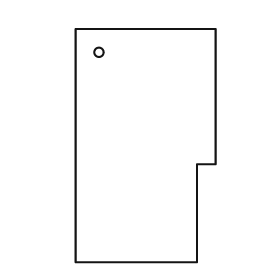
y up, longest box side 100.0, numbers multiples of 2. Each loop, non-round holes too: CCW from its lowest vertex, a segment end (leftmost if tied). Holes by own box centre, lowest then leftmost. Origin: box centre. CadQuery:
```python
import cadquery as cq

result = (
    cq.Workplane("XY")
    .moveTo(-30.0, -50.0)
    .lineTo(22.0, -50.0)
    .lineTo(22.0, -8.0)
    .lineTo(30.0, -8.0)
    .lineTo(30.0, 50.0)
    .lineTo(-30.0, 50.0)
    .close()
    .moveTo(-20.0, 40.0)
    .circle(2.0)
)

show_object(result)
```